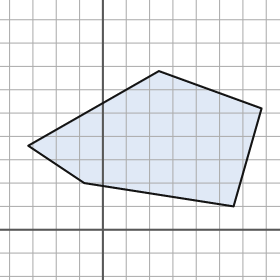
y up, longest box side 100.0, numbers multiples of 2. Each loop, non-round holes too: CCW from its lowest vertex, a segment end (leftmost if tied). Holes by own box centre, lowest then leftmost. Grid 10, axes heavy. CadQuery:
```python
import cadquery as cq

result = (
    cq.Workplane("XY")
    .moveTo(56.0, 10.0)
    .lineTo(68.0, 52.0)
    .lineTo(24.0, 68.0)
    .lineTo(-32.0, 36.0)
    .lineTo(-8.0, 20.0)
    .close()
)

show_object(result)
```